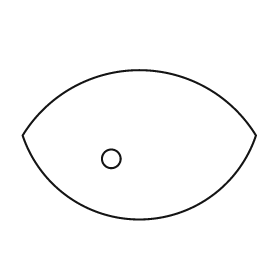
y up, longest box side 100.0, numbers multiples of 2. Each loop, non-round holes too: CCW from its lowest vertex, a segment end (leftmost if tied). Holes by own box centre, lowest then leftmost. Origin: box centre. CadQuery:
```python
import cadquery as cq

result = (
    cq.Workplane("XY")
    .moveTo(-50.0, 4.0)
    .threePointArc((0.0, -32.0), (50.0, 4.0))
    .threePointArc((0.0, 32.0), (-50.0, 4.0))
    .close()
    .moveTo(-12.0, -6.0)
    .circle(4.0)
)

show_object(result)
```